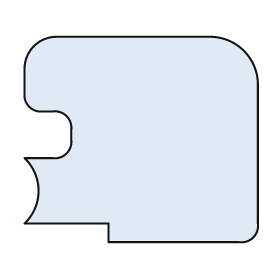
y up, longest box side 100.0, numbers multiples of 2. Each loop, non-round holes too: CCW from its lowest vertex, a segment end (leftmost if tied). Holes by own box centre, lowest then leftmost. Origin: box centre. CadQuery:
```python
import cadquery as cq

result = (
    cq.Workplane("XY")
    .moveTo(-14.0, -44.0)
    .lineTo(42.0, -44.0)
    .threePointArc((48.0, -42.0), (50.0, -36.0))
    .lineTo(50.0, 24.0)
    .threePointArc((44.0, 38.0), (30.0, 44.0))
    .lineTo(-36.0, 44.0)
    .threePointArc((-46.0, 40.0), (-50.0, 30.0))
    .lineTo(-50.0, 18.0)
    .threePointArc((-48.0, 14.0), (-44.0, 12.0))
    .lineTo(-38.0, 12.0)
    .threePointArc((-32.0, 10.0), (-30.0, 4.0))
    .lineTo(-30.0, 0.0)
    .threePointArc((-32.0, -6.0), (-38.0, -8.0))
    .lineTo(-50.0, -8.0)
    .threePointArc((-44.0, -22.0), (-50.0, -36.0))
    .lineTo(-14.0, -36.0)
    .close()
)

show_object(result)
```